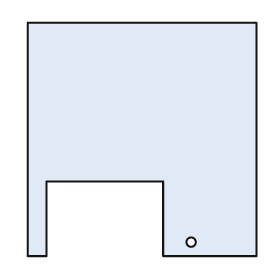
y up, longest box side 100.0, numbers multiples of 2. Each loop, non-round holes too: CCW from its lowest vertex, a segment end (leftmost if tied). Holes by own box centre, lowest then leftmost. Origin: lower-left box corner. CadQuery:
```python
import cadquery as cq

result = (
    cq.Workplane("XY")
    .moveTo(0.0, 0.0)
    .lineTo(8.0, 0.0)
    .lineTo(8.0, 32.0)
    .lineTo(58.0, 32.0)
    .lineTo(58.0, 0.0)
    .lineTo(98.0, 0.0)
    .lineTo(98.0, 100.0)
    .lineTo(0.0, 100.0)
    .close()
    .moveTo(70.0, 6.0)
    .circle(2.0)
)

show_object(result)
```